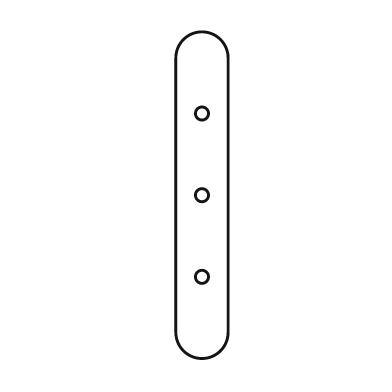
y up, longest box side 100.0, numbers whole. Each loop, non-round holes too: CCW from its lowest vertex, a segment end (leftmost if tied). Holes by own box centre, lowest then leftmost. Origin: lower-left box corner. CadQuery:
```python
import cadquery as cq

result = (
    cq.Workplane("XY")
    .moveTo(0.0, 8.0)
    .threePointArc((8.0, 0.0), (16.0, 8.0))
    .lineTo(16.0, 92.0)
    .threePointArc((8.0, 100.0), (0.0, 92.0))
    .close()
    .moveTo(8.0, 25.0)
    .circle(2.0)
    .moveTo(8.0, 50.0)
    .circle(2.0)
    .moveTo(8.0, 75.0)
    .circle(2.0)
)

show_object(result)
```